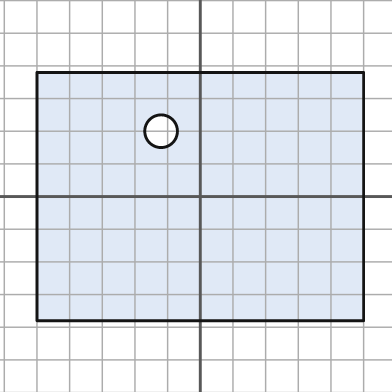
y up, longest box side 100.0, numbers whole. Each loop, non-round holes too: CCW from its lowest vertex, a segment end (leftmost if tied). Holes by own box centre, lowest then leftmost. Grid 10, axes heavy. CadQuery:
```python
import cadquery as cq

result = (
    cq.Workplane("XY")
    .moveTo(-50.0, -38.0)
    .lineTo(50.0, -38.0)
    .lineTo(50.0, 38.0)
    .lineTo(-50.0, 38.0)
    .close()
    .moveTo(-12.0, 20.0)
    .circle(5.0)
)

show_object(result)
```